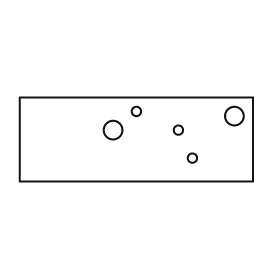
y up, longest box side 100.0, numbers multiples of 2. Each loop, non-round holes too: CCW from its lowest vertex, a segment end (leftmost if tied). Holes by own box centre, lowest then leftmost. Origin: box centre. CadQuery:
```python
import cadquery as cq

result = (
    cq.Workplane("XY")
    .moveTo(-50.0, -18.0)
    .lineTo(50.0, -18.0)
    .lineTo(50.0, 18.0)
    .lineTo(-50.0, 18.0)
    .close()
    .moveTo(24.0, -8.0)
    .circle(2.0)
    .moveTo(-10.0, 4.0)
    .circle(4.0)
    .moveTo(18.0, 4.0)
    .circle(2.0)
    .moveTo(42.0, 10.0)
    .circle(4.0)
    .moveTo(0.0, 12.0)
    .circle(2.0)
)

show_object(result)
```